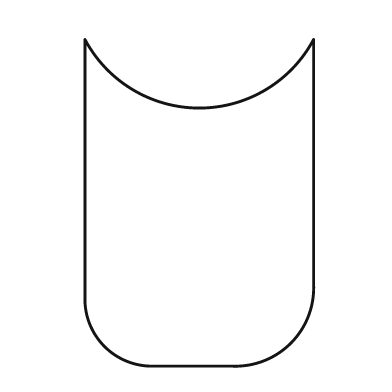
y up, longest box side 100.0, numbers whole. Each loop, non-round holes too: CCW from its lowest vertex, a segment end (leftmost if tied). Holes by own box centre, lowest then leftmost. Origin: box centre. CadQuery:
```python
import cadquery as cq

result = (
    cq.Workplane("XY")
    .moveTo(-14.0, -50.0)
    .lineTo(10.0, -50.0)
    .threePointArc((28.0, -43.0), (35.0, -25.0))
    .lineTo(35.0, 50.0)
    .threePointArc((0.0, 29.0), (-35.0, 50.0))
    .lineTo(-35.0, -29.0)
    .threePointArc((-29.0, -44.0), (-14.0, -50.0))
    .close()
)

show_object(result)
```